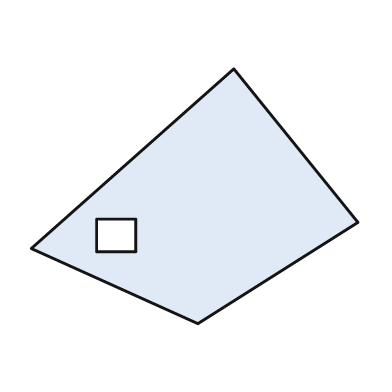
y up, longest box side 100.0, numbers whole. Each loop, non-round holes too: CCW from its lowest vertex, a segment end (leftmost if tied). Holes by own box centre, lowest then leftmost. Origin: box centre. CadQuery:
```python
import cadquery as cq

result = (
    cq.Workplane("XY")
    .moveTo(1.0, -39.0)
    .lineTo(50.0, -8.0)
    .lineTo(12.0, 39.0)
    .lineTo(-50.0, -16.0)
    .close()
    .moveTo(-30.0, -17.0)
    .lineTo(-18.0, -17.0)
    .lineTo(-18.0, -7.0)
    .lineTo(-30.0, -7.0)
    .close()
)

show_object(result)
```